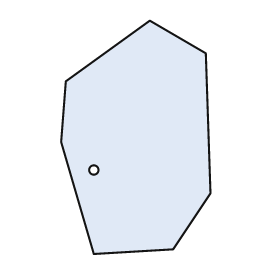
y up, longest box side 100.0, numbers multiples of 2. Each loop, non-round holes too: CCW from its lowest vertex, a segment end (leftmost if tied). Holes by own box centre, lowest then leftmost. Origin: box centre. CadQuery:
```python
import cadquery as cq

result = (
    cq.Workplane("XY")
    .moveTo(-18.0, -50.0)
    .lineTo(16.0, -48.0)
    .lineTo(32.0, -24.0)
    .lineTo(30.0, 36.0)
    .lineTo(6.0, 50.0)
    .lineTo(-30.0, 24.0)
    .lineTo(-32.0, -2.0)
    .close()
    .moveTo(-18.0, -14.0)
    .circle(2.0)
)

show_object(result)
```